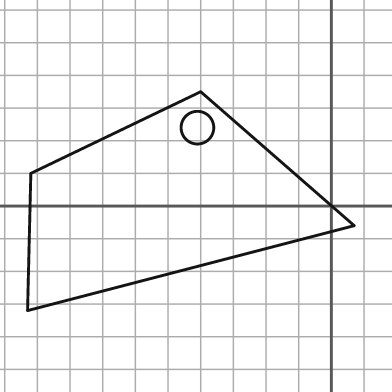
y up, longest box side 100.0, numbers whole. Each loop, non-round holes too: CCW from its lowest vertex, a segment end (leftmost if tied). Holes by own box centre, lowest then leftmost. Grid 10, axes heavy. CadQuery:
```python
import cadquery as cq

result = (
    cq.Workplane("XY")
    .moveTo(-93.0, -32.0)
    .lineTo(7.0, -6.0)
    .lineTo(-40.0, 35.0)
    .lineTo(-92.0, 10.0)
    .close()
    .moveTo(-41.0, 24.0)
    .circle(5.0)
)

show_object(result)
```